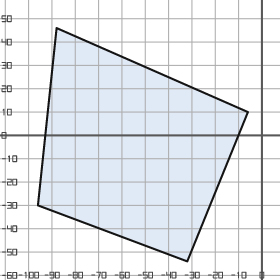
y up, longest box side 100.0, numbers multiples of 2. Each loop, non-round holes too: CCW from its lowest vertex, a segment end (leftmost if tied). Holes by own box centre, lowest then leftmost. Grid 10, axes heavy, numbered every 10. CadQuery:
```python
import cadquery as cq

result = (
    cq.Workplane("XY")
    .moveTo(-32.0, -54.0)
    .lineTo(-6.0, 10.0)
    .lineTo(-88.0, 46.0)
    .lineTo(-96.0, -30.0)
    .close()
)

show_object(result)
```